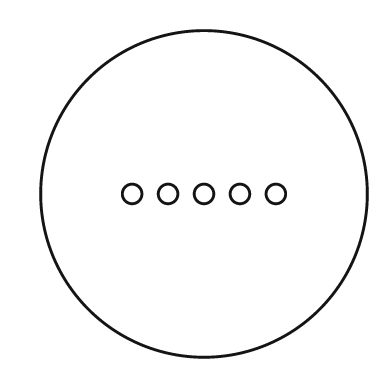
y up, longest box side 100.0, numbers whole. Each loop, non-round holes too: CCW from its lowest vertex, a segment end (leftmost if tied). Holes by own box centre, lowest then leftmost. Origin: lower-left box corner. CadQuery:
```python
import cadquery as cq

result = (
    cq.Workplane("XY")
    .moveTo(50.0, 50.0)
    .circle(50.0)
    .moveTo(28.0, 50.0)
    .circle(3.0)
    .moveTo(39.0, 50.0)
    .circle(3.0)
    .moveTo(50.0, 50.0)
    .circle(3.0)
    .moveTo(61.0, 50.0)
    .circle(3.0)
    .moveTo(72.0, 50.0)
    .circle(3.0)
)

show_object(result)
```